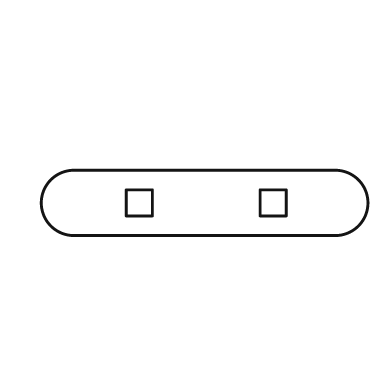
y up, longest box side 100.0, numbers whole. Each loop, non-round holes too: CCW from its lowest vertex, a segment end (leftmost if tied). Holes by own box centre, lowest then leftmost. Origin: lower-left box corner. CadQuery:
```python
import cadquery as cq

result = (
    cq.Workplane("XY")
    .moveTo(10.0, 0.0)
    .lineTo(90.0, 0.0)
    .threePointArc((100.0, 10.0), (90.0, 20.0))
    .lineTo(10.0, 20.0)
    .threePointArc((0.0, 10.0), (10.0, 0.0))
    .close()
    .moveTo(26.0, 6.0)
    .lineTo(34.0, 6.0)
    .lineTo(34.0, 14.0)
    .lineTo(26.0, 14.0)
    .close()
    .moveTo(67.0, 6.0)
    .lineTo(75.0, 6.0)
    .lineTo(75.0, 14.0)
    .lineTo(67.0, 14.0)
    .close()
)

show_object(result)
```